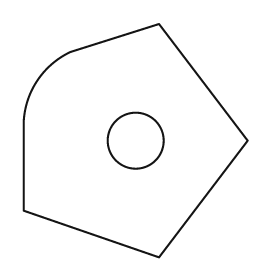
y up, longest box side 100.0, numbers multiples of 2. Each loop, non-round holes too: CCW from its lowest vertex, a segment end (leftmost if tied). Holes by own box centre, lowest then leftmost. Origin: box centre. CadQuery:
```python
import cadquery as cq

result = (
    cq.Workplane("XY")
    .moveTo(10.0, -50.0)
    .lineTo(48.0, 0.0)
    .lineTo(10.0, 50.0)
    .lineTo(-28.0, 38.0)
    .threePointArc((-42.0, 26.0), (-48.0, 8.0))
    .lineTo(-48.0, -30.0)
    .close()
    .moveTo(0.0, 0.0)
    .circle(12.0)
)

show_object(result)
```